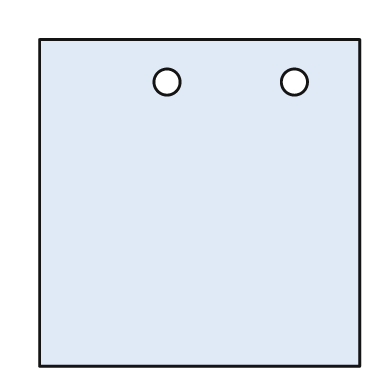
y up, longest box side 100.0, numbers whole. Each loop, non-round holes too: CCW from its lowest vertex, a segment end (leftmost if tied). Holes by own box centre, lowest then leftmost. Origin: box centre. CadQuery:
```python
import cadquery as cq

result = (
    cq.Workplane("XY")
    .moveTo(-49.0, -50.0)
    .lineTo(49.0, -50.0)
    .lineTo(49.0, 50.0)
    .lineTo(-49.0, 50.0)
    .close()
    .moveTo(-10.0, 37.0)
    .circle(4.0)
    .moveTo(29.0, 37.0)
    .circle(4.0)
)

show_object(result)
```